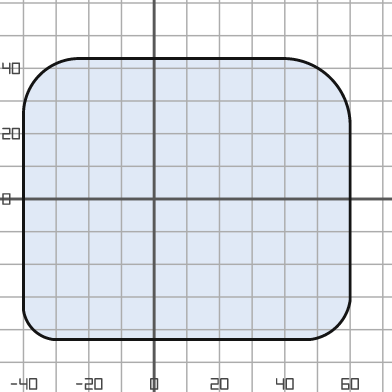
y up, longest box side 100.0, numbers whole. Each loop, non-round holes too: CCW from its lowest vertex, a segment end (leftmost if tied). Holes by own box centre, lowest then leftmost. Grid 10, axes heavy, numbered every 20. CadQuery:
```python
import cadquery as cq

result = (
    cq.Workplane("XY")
    .moveTo(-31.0, -43.0)
    .lineTo(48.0, -43.0)
    .threePointArc((56.0, -39.0), (60.0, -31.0))
    .lineTo(60.0, 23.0)
    .threePointArc((54.0, 37.0), (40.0, 43.0))
    .lineTo(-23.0, 43.0)
    .threePointArc((-35.0, 38.0), (-40.0, 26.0))
    .lineTo(-40.0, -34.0)
    .threePointArc((-37.0, -40.0), (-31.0, -43.0))
    .close()
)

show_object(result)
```